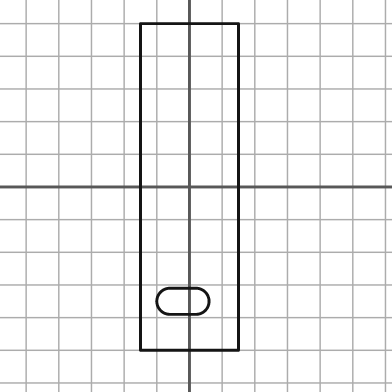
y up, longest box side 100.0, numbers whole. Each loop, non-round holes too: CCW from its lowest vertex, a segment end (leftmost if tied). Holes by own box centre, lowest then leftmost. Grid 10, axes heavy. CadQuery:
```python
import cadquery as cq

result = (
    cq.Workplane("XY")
    .moveTo(-15.0, -50.0)
    .lineTo(15.0, -50.0)
    .lineTo(15.0, 50.0)
    .lineTo(-15.0, 50.0)
    .close()
    .moveTo(-6.0, -39.0)
    .lineTo(2.0, -39.0)
    .threePointArc((6.0, -35.0), (2.0, -31.0))
    .lineTo(-6.0, -31.0)
    .threePointArc((-10.0, -35.0), (-6.0, -39.0))
    .close()
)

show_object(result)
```